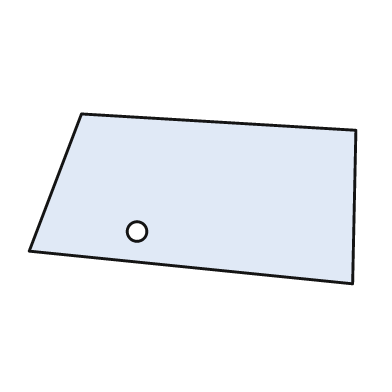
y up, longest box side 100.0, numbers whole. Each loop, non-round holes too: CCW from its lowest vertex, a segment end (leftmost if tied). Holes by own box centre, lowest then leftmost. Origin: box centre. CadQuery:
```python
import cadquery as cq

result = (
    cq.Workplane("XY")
    .moveTo(49.0, -26.0)
    .lineTo(50.0, 21.0)
    .lineTo(-34.0, 26.0)
    .lineTo(-50.0, -16.0)
    .close()
    .moveTo(-17.0, -10.0)
    .circle(3.0)
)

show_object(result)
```